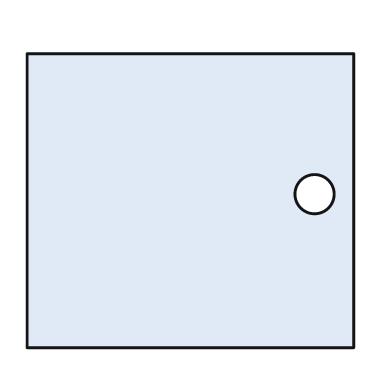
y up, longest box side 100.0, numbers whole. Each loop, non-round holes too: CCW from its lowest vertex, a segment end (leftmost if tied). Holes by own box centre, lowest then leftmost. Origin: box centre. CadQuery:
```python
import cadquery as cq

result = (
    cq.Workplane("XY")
    .moveTo(-50.0, -45.0)
    .lineTo(50.0, -45.0)
    .lineTo(50.0, 45.0)
    .lineTo(-50.0, 45.0)
    .close()
    .moveTo(38.0, 2.0)
    .circle(6.0)
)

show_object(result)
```